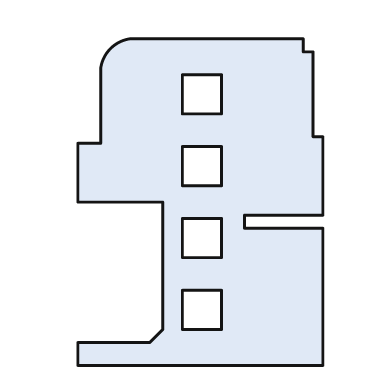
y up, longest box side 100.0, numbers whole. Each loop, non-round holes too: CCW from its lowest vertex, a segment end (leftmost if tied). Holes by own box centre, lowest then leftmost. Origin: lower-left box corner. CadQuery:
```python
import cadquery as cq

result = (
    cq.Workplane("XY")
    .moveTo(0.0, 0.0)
    .lineTo(75.0, 0.0)
    .lineTo(75.0, 42.0)
    .lineTo(51.0, 42.0)
    .lineTo(51.0, 46.0)
    .lineTo(75.0, 46.0)
    .lineTo(75.0, 70.0)
    .lineTo(72.0, 70.0)
    .lineTo(72.0, 96.0)
    .lineTo(69.0, 96.0)
    .lineTo(69.0, 100.0)
    .lineTo(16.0, 100.0)
    .threePointArc((10.0, 97.0), (7.0, 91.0))
    .lineTo(7.0, 68.0)
    .lineTo(0.0, 68.0)
    .lineTo(0.0, 50.0)
    .lineTo(26.0, 50.0)
    .lineTo(26.0, 11.0)
    .lineTo(22.0, 7.0)
    .lineTo(0.0, 7.0)
    .close()
    .moveTo(32.0, 11.0)
    .lineTo(44.0, 11.0)
    .lineTo(44.0, 23.0)
    .lineTo(32.0, 23.0)
    .close()
    .moveTo(32.0, 33.0)
    .lineTo(44.0, 33.0)
    .lineTo(44.0, 45.0)
    .lineTo(32.0, 45.0)
    .close()
    .moveTo(32.0, 55.0)
    .lineTo(44.0, 55.0)
    .lineTo(44.0, 67.0)
    .lineTo(32.0, 67.0)
    .close()
    .moveTo(32.0, 77.0)
    .lineTo(44.0, 77.0)
    .lineTo(44.0, 89.0)
    .lineTo(32.0, 89.0)
    .close()
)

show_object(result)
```